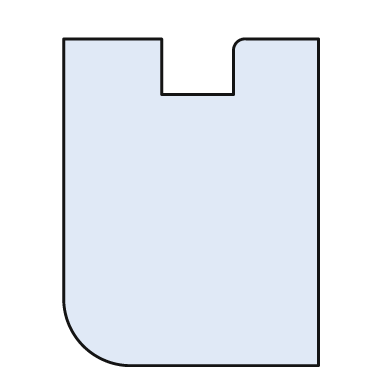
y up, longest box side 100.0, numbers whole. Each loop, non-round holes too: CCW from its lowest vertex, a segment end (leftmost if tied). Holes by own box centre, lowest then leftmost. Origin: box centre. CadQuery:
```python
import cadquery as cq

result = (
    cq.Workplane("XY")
    .moveTo(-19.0, -50.0)
    .lineTo(39.0, -50.0)
    .lineTo(39.0, 50.0)
    .lineTo(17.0, 50.0)
    .threePointArc((14.0, 49.0), (13.0, 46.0))
    .lineTo(13.0, 33.0)
    .lineTo(-9.0, 33.0)
    .lineTo(-9.0, 50.0)
    .lineTo(-39.0, 50.0)
    .lineTo(-39.0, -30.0)
    .threePointArc((-33.0, -44.0), (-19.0, -50.0))
    .close()
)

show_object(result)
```